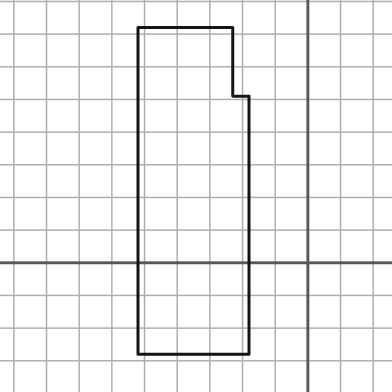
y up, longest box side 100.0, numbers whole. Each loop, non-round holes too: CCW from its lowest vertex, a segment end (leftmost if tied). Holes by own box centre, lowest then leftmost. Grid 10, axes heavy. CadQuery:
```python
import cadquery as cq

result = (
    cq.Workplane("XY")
    .moveTo(-52.0, -28.0)
    .lineTo(-18.0, -28.0)
    .lineTo(-18.0, 51.0)
    .lineTo(-23.0, 51.0)
    .lineTo(-23.0, 72.0)
    .lineTo(-52.0, 72.0)
    .close()
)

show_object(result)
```